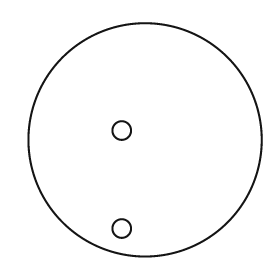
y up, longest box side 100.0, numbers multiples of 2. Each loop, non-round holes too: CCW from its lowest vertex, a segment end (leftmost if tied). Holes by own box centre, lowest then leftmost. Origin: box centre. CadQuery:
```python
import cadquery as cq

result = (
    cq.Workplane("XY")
    .moveTo(0.0, 0.0)
    .circle(50.0)
    .moveTo(-10.0, -38.0)
    .circle(4.0)
    .moveTo(-10.0, 4.0)
    .circle(4.0)
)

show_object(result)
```